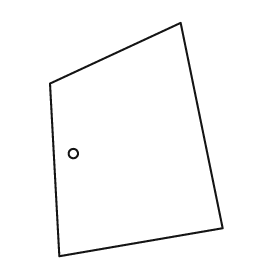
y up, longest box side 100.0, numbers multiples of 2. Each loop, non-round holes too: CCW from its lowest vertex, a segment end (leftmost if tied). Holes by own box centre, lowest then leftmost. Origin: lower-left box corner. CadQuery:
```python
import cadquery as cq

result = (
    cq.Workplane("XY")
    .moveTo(4.0, 0.0)
    .lineTo(74.0, 12.0)
    .lineTo(56.0, 100.0)
    .lineTo(0.0, 74.0)
    .close()
    .moveTo(10.0, 44.0)
    .circle(2.0)
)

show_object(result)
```